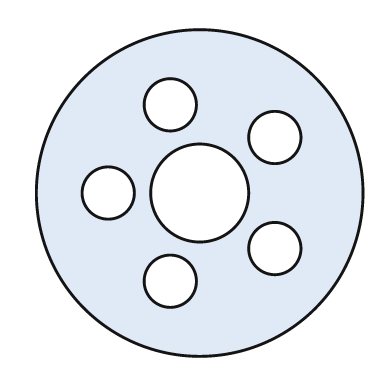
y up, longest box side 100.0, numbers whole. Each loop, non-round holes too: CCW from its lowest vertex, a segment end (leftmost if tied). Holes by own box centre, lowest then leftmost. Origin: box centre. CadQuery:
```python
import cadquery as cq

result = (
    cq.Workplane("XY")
    .moveTo(0.0, 0.0)
    .circle(50.0)
    .moveTo(-9.0, -27.0)
    .circle(8.0)
    .moveTo(23.0, -17.0)
    .circle(8.0)
    .moveTo(-28.0, 0.0)
    .circle(8.0)
    .moveTo(0.0, 0.0)
    .circle(15.0)
    .moveTo(23.0, 17.0)
    .circle(8.0)
    .moveTo(-9.0, 27.0)
    .circle(8.0)
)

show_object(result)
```